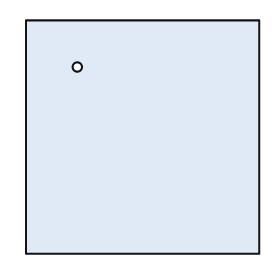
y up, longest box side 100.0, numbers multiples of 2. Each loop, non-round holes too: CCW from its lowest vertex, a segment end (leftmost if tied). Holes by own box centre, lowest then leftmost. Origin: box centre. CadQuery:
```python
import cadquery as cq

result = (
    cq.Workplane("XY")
    .moveTo(-50.0, -50.0)
    .lineTo(50.0, -50.0)
    .lineTo(50.0, 50.0)
    .lineTo(-50.0, 50.0)
    .close()
    .moveTo(-28.0, 30.0)
    .circle(2.0)
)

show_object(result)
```